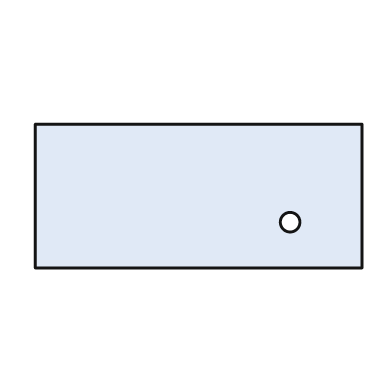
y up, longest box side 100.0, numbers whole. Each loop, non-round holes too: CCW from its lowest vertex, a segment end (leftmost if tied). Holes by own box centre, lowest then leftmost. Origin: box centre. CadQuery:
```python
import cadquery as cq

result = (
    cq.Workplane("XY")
    .moveTo(-50.0, -22.0)
    .lineTo(50.0, -22.0)
    .lineTo(50.0, 22.0)
    .lineTo(-50.0, 22.0)
    .close()
    .moveTo(28.0, -8.0)
    .circle(3.0)
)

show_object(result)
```